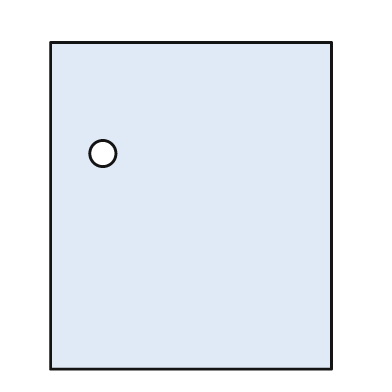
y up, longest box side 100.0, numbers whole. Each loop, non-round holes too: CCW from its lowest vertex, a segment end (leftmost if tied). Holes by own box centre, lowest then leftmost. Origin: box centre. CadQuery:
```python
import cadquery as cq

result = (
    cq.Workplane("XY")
    .moveTo(-43.0, -50.0)
    .lineTo(43.0, -50.0)
    .lineTo(43.0, 50.0)
    .lineTo(-43.0, 50.0)
    .close()
    .moveTo(-27.0, 16.0)
    .circle(4.0)
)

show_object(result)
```